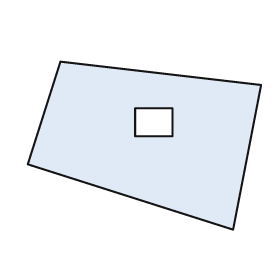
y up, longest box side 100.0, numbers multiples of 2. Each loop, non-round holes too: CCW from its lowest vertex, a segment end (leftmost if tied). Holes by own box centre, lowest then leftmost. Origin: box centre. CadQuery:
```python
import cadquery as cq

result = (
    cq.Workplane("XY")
    .moveTo(38.0, -36.0)
    .lineTo(50.0, 26.0)
    .lineTo(-36.0, 36.0)
    .lineTo(-50.0, -8.0)
    .close()
    .moveTo(-4.0, 4.0)
    .lineTo(12.0, 4.0)
    .lineTo(12.0, 16.0)
    .lineTo(-4.0, 16.0)
    .close()
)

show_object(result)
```